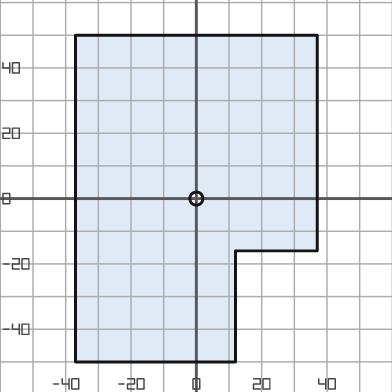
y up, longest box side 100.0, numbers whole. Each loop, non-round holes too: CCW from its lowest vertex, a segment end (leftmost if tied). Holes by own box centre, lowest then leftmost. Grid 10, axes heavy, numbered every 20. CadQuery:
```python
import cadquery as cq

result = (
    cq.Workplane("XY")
    .moveTo(-37.0, -50.0)
    .lineTo(12.0, -50.0)
    .lineTo(12.0, -16.0)
    .lineTo(37.0, -16.0)
    .lineTo(37.0, 50.0)
    .lineTo(-37.0, 50.0)
    .close()
    .moveTo(0.0, 0.0)
    .circle(2.0)
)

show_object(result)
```